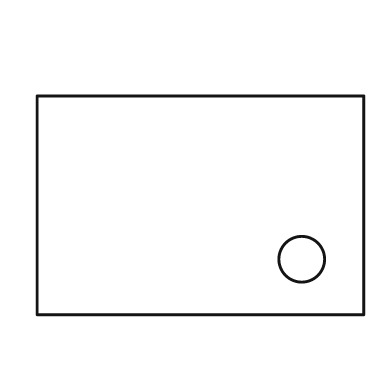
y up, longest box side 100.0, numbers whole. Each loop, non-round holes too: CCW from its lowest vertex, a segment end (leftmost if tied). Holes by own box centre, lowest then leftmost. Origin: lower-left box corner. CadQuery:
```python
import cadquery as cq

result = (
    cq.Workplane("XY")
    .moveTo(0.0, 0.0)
    .lineTo(100.0, 0.0)
    .lineTo(100.0, 67.0)
    .lineTo(0.0, 67.0)
    .close()
    .moveTo(81.0, 17.0)
    .circle(7.0)
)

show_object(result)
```